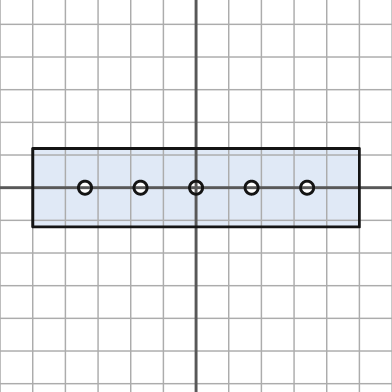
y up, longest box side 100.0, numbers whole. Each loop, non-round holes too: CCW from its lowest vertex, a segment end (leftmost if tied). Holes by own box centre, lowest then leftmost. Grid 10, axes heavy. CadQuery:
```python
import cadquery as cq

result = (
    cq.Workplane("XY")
    .moveTo(-50.0, -12.0)
    .lineTo(50.0, -12.0)
    .lineTo(50.0, 12.0)
    .lineTo(-50.0, 12.0)
    .close()
    .moveTo(-34.0, 0.0)
    .circle(2.0)
    .moveTo(-17.0, 0.0)
    .circle(2.0)
    .moveTo(0.0, 0.0)
    .circle(2.0)
    .moveTo(17.0, 0.0)
    .circle(2.0)
    .moveTo(34.0, 0.0)
    .circle(2.0)
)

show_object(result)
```